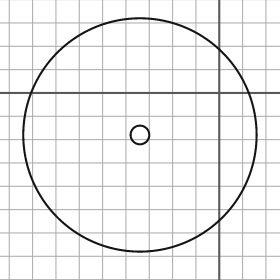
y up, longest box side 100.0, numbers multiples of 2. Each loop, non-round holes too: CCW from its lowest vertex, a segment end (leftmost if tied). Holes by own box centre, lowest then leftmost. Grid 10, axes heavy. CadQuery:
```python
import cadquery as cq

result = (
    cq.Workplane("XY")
    .moveTo(-34.0, -18.0)
    .circle(50.0)
    .moveTo(-34.0, -18.0)
    .circle(4.0)
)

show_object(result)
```